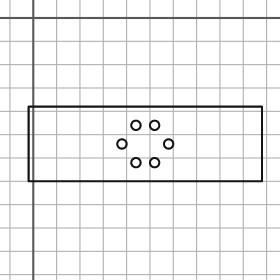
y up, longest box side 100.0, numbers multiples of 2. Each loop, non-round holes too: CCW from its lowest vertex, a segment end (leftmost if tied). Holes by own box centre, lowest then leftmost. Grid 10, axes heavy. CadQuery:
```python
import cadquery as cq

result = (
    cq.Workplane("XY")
    .moveTo(-2.0, -70.0)
    .lineTo(98.0, -70.0)
    .lineTo(98.0, -38.0)
    .lineTo(-2.0, -38.0)
    .close()
    .moveTo(44.0, -62.0)
    .circle(2.0)
    .moveTo(52.0, -62.0)
    .circle(2.0)
    .moveTo(38.0, -54.0)
    .circle(2.0)
    .moveTo(58.0, -54.0)
    .circle(2.0)
    .moveTo(44.0, -46.0)
    .circle(2.0)
    .moveTo(52.0, -46.0)
    .circle(2.0)
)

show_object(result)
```